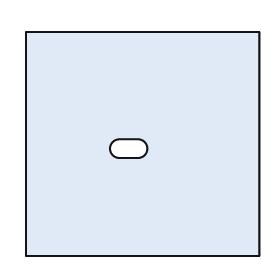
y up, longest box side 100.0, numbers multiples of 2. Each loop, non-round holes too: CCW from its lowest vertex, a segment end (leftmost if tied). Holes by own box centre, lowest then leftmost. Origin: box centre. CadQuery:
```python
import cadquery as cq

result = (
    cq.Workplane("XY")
    .moveTo(-50.0, -48.0)
    .lineTo(50.0, -48.0)
    .lineTo(50.0, 48.0)
    .lineTo(-50.0, 48.0)
    .close()
    .moveTo(-10.0, -6.0)
    .lineTo(-2.0, -6.0)
    .threePointArc((2.0, -2.0), (-2.0, 2.0))
    .lineTo(-10.0, 2.0)
    .threePointArc((-14.0, -2.0), (-10.0, -6.0))
    .close()
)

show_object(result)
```